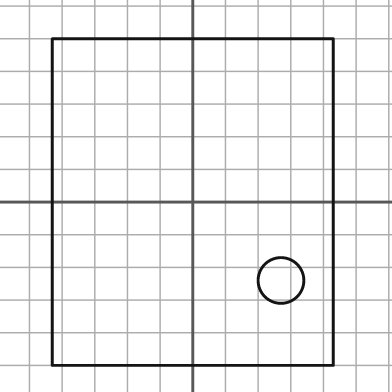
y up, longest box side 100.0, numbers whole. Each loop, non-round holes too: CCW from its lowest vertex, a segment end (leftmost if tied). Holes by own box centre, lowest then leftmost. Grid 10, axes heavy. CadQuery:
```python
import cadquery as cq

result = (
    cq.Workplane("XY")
    .moveTo(-43.0, -50.0)
    .lineTo(43.0, -50.0)
    .lineTo(43.0, 50.0)
    .lineTo(-43.0, 50.0)
    .close()
    .moveTo(27.0, -24.0)
    .circle(7.0)
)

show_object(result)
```